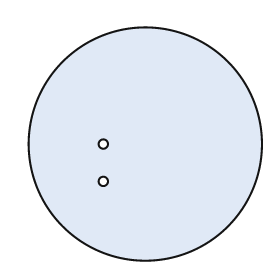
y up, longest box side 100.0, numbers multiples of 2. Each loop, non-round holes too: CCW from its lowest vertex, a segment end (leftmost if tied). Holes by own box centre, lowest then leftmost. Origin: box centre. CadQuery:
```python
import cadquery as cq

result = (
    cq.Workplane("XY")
    .moveTo(0.0, 0.0)
    .circle(50.0)
    .moveTo(-18.0, -16.0)
    .circle(2.0)
    .moveTo(-18.0, 0.0)
    .circle(2.0)
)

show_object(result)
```